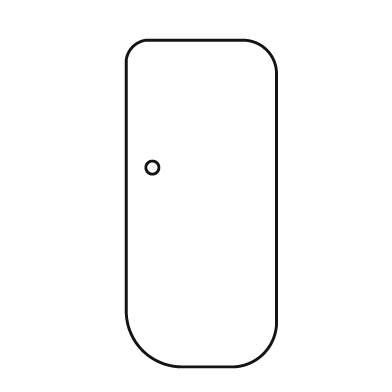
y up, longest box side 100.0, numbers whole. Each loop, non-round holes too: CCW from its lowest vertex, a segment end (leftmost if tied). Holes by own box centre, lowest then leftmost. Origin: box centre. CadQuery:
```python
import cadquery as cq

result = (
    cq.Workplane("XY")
    .moveTo(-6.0, -50.0)
    .lineTo(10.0, -50.0)
    .threePointArc((19.0, -46.0), (23.0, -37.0))
    .lineTo(23.0, 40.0)
    .threePointArc((20.0, 47.0), (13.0, 50.0))
    .lineTo(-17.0, 50.0)
    .threePointArc((-21.0, 48.0), (-23.0, 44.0))
    .lineTo(-23.0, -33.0)
    .threePointArc((-18.0, -45.0), (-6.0, -50.0))
    .close()
    .moveTo(-15.0, 11.0)
    .circle(2.0)
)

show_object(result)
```